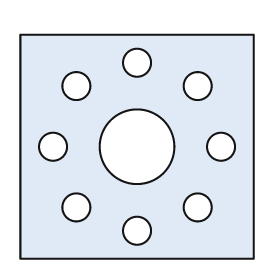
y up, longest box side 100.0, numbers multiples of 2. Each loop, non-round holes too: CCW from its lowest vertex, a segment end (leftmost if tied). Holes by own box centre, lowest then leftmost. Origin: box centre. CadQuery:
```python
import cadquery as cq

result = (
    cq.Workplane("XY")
    .moveTo(-50.0, -48.0)
    .lineTo(50.0, -48.0)
    .lineTo(50.0, 48.0)
    .lineTo(-50.0, 48.0)
    .close()
    .moveTo(0.0, -36.0)
    .circle(6.0)
    .moveTo(-26.0, -26.0)
    .circle(6.0)
    .moveTo(26.0, -26.0)
    .circle(6.0)
    .moveTo(-36.0, 0.0)
    .circle(6.0)
    .moveTo(0.0, 0.0)
    .circle(16.0)
    .moveTo(36.0, 0.0)
    .circle(6.0)
    .moveTo(-26.0, 26.0)
    .circle(6.0)
    .moveTo(26.0, 26.0)
    .circle(6.0)
    .moveTo(0.0, 36.0)
    .circle(6.0)
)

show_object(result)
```